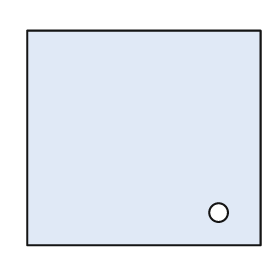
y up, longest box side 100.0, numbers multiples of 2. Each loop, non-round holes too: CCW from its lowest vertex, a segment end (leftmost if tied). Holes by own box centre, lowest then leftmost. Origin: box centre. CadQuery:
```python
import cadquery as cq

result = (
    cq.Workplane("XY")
    .moveTo(-50.0, -46.0)
    .lineTo(50.0, -46.0)
    .lineTo(50.0, 46.0)
    .lineTo(-50.0, 46.0)
    .close()
    .moveTo(32.0, -32.0)
    .circle(4.0)
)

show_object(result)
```